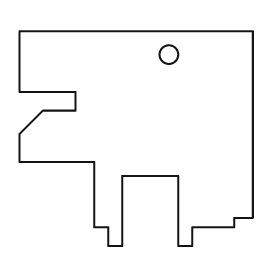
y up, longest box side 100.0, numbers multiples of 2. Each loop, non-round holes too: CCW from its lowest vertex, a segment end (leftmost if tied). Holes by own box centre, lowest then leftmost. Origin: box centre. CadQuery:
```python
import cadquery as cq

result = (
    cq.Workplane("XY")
    .moveTo(-12.0, -46.0)
    .lineTo(-6.0, -46.0)
    .lineTo(-6.0, -16.0)
    .lineTo(18.0, -16.0)
    .lineTo(18.0, -46.0)
    .lineTo(24.0, -46.0)
    .lineTo(24.0, -38.0)
    .lineTo(42.0, -38.0)
    .lineTo(42.0, -34.0)
    .lineTo(50.0, -34.0)
    .lineTo(50.0, 46.0)
    .lineTo(-50.0, 46.0)
    .lineTo(-50.0, 20.0)
    .lineTo(-26.0, 20.0)
    .lineTo(-26.0, 12.0)
    .lineTo(-40.0, 12.0)
    .lineTo(-50.0, 2.0)
    .lineTo(-50.0, -10.0)
    .lineTo(-18.0, -10.0)
    .lineTo(-18.0, -38.0)
    .lineTo(-12.0, -38.0)
    .close()
    .moveTo(14.0, 36.0)
    .circle(4.0)
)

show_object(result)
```